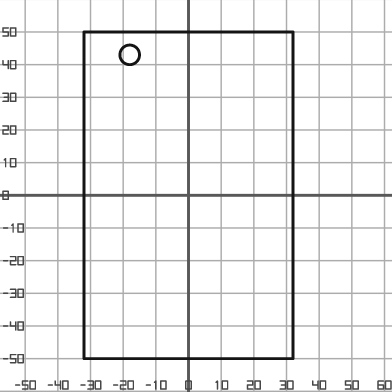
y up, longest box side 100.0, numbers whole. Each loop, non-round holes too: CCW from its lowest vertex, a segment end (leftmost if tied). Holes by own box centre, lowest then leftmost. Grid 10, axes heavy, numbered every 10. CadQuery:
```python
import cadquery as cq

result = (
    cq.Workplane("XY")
    .moveTo(-32.0, -50.0)
    .lineTo(32.0, -50.0)
    .lineTo(32.0, 50.0)
    .lineTo(-32.0, 50.0)
    .close()
    .moveTo(-18.0, 43.0)
    .circle(3.0)
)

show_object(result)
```